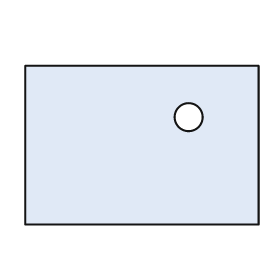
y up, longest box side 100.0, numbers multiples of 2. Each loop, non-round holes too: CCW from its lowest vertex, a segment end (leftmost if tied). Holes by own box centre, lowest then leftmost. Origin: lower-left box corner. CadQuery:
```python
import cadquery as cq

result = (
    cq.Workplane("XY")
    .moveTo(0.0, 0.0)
    .lineTo(100.0, 0.0)
    .lineTo(100.0, 68.0)
    .lineTo(0.0, 68.0)
    .close()
    .moveTo(70.0, 46.0)
    .circle(6.0)
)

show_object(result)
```